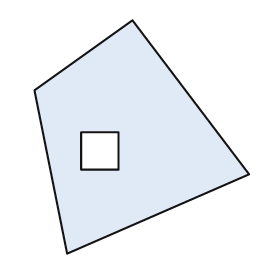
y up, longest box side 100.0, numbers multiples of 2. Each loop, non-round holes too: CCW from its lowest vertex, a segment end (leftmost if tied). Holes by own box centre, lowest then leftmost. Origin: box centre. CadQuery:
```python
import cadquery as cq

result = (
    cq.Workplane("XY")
    .moveTo(-32.0, -50.0)
    .lineTo(46.0, -16.0)
    .lineTo(-4.0, 50.0)
    .lineTo(-46.0, 20.0)
    .close()
    .moveTo(-26.0, -14.0)
    .lineTo(-10.0, -14.0)
    .lineTo(-10.0, 2.0)
    .lineTo(-26.0, 2.0)
    .close()
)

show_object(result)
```